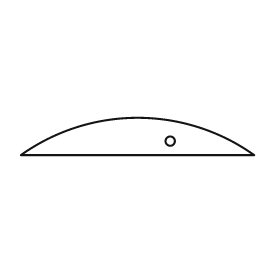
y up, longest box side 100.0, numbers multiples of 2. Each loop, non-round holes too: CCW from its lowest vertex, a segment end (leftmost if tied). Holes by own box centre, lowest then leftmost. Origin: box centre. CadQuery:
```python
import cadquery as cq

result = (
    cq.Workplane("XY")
    .moveTo(-50.0, -8.0)
    .lineTo(50.0, -8.0)
    .threePointArc((0.0, 8.0), (-50.0, -8.0))
    .close()
    .moveTo(14.0, -2.0)
    .circle(2.0)
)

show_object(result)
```